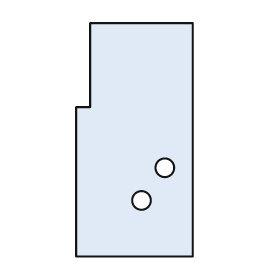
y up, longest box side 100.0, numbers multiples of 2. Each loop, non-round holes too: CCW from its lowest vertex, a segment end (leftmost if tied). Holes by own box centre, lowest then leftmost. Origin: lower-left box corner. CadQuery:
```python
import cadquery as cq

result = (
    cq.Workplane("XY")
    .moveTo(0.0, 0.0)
    .lineTo(50.0, 0.0)
    .lineTo(50.0, 100.0)
    .lineTo(6.0, 100.0)
    .lineTo(6.0, 64.0)
    .lineTo(0.0, 64.0)
    .close()
    .moveTo(28.0, 24.0)
    .circle(4.0)
    .moveTo(38.0, 38.0)
    .circle(4.0)
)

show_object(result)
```